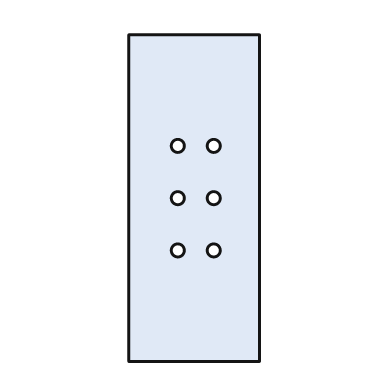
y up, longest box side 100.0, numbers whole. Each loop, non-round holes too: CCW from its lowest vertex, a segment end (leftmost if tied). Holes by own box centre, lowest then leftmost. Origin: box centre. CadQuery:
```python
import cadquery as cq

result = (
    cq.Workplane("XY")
    .moveTo(-20.0, -50.0)
    .lineTo(20.0, -50.0)
    .lineTo(20.0, 50.0)
    .lineTo(-20.0, 50.0)
    .close()
    .moveTo(-5.0, -16.0)
    .circle(2.0)
    .moveTo(6.0, -16.0)
    .circle(2.0)
    .moveTo(-5.0, 0.0)
    .circle(2.0)
    .moveTo(6.0, 0.0)
    .circle(2.0)
    .moveTo(-5.0, 16.0)
    .circle(2.0)
    .moveTo(6.0, 16.0)
    .circle(2.0)
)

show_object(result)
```